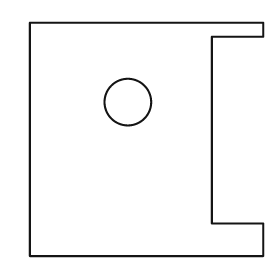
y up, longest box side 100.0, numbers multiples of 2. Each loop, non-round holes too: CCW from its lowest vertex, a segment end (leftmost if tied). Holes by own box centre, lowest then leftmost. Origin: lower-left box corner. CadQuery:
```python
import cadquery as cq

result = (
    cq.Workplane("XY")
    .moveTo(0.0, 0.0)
    .lineTo(100.0, 0.0)
    .lineTo(100.0, 14.0)
    .lineTo(78.0, 14.0)
    .lineTo(78.0, 94.0)
    .lineTo(100.0, 94.0)
    .lineTo(100.0, 100.0)
    .lineTo(0.0, 100.0)
    .close()
    .moveTo(42.0, 66.0)
    .circle(10.0)
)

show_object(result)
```